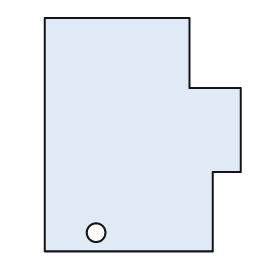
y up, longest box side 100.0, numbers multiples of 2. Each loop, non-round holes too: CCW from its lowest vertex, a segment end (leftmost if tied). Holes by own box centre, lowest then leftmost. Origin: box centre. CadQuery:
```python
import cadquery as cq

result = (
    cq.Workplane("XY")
    .moveTo(-42.0, -50.0)
    .lineTo(30.0, -50.0)
    .lineTo(30.0, -16.0)
    .lineTo(42.0, -16.0)
    .lineTo(42.0, 20.0)
    .lineTo(20.0, 20.0)
    .lineTo(20.0, 50.0)
    .lineTo(-42.0, 50.0)
    .close()
    .moveTo(-20.0, -42.0)
    .circle(4.0)
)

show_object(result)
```